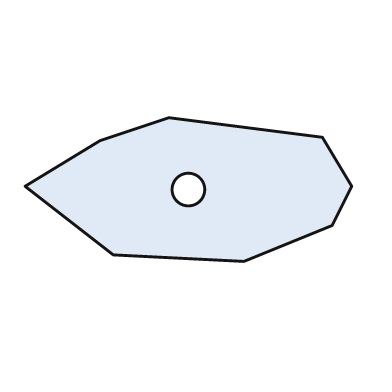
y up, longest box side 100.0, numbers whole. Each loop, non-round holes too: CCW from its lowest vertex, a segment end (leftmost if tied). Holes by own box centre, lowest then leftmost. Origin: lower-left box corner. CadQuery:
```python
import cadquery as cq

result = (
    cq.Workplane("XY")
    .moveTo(67.0, 0.0)
    .lineTo(94.0, 11.0)
    .lineTo(100.0, 23.0)
    .lineTo(91.0, 38.0)
    .lineTo(44.0, 44.0)
    .lineTo(23.0, 37.0)
    .lineTo(0.0, 23.0)
    .lineTo(27.0, 2.0)
    .close()
    .moveTo(50.0, 22.0)
    .circle(5.0)
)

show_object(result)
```